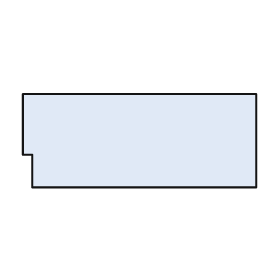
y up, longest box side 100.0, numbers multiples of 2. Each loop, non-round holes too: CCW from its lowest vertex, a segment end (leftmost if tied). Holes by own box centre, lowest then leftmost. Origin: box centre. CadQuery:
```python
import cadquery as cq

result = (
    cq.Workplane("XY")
    .moveTo(-46.0, -20.0)
    .lineTo(50.0, -20.0)
    .lineTo(50.0, 20.0)
    .lineTo(-50.0, 20.0)
    .lineTo(-50.0, -6.0)
    .lineTo(-46.0, -6.0)
    .close()
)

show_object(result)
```